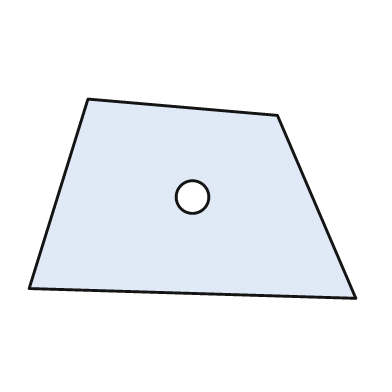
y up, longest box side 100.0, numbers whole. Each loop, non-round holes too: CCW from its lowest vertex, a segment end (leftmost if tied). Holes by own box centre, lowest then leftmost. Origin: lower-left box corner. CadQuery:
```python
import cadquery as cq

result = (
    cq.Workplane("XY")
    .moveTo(100.0, 0.0)
    .lineTo(76.0, 56.0)
    .lineTo(18.0, 61.0)
    .lineTo(0.0, 3.0)
    .close()
    .moveTo(50.0, 31.0)
    .circle(5.0)
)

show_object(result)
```